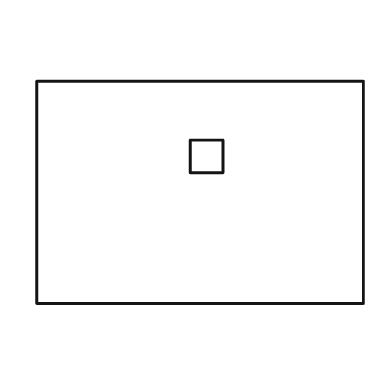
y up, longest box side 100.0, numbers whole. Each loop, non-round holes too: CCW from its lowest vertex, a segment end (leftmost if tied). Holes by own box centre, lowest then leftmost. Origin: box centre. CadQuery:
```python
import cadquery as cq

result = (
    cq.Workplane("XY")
    .moveTo(-50.0, -34.0)
    .lineTo(50.0, -34.0)
    .lineTo(50.0, 34.0)
    .lineTo(-50.0, 34.0)
    .close()
    .moveTo(-3.0, 6.0)
    .lineTo(7.0, 6.0)
    .lineTo(7.0, 16.0)
    .lineTo(-3.0, 16.0)
    .close()
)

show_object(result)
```